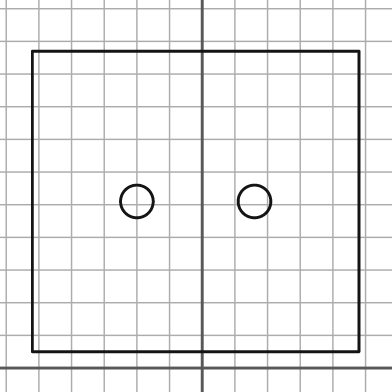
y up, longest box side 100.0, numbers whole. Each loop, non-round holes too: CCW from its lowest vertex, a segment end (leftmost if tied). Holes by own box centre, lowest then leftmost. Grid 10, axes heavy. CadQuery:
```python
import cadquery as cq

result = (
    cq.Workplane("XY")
    .moveTo(-52.0, 5.0)
    .lineTo(48.0, 5.0)
    .lineTo(48.0, 97.0)
    .lineTo(-52.0, 97.0)
    .close()
    .moveTo(-20.0, 51.0)
    .circle(5.0)
    .moveTo(16.0, 51.0)
    .circle(5.0)
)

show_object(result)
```